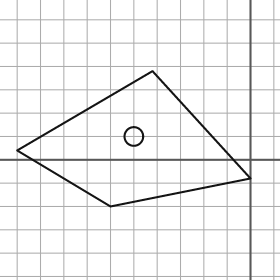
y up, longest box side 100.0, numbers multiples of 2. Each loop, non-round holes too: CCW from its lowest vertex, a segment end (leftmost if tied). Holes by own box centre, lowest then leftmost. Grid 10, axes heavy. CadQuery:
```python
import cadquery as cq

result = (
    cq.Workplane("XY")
    .moveTo(-60.0, -20.0)
    .lineTo(0.0, -8.0)
    .lineTo(-42.0, 38.0)
    .lineTo(-100.0, 4.0)
    .close()
    .moveTo(-50.0, 10.0)
    .circle(4.0)
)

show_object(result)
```